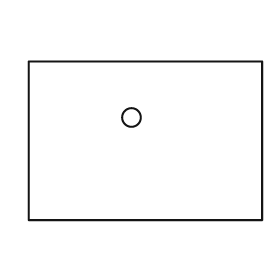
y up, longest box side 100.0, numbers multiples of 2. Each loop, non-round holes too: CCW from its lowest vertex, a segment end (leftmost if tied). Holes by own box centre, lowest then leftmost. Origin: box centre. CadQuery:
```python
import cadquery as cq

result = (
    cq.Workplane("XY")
    .moveTo(-50.0, -34.0)
    .lineTo(50.0, -34.0)
    .lineTo(50.0, 34.0)
    .lineTo(-50.0, 34.0)
    .close()
    .moveTo(-6.0, 10.0)
    .circle(4.0)
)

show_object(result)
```